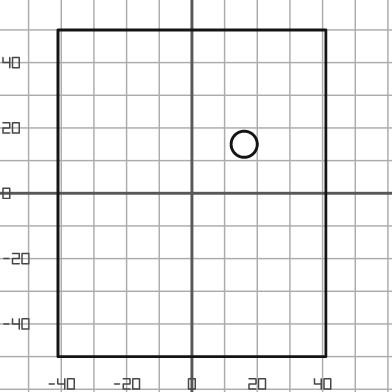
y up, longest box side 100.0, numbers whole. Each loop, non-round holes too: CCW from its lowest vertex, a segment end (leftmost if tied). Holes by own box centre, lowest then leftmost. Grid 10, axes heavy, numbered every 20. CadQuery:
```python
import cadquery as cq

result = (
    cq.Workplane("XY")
    .moveTo(-41.0, -50.0)
    .lineTo(41.0, -50.0)
    .lineTo(41.0, 50.0)
    .lineTo(-41.0, 50.0)
    .close()
    .moveTo(16.0, 15.0)
    .circle(4.0)
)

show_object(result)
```